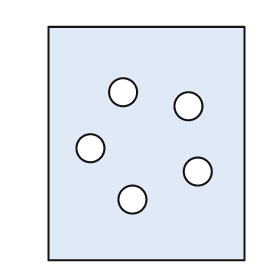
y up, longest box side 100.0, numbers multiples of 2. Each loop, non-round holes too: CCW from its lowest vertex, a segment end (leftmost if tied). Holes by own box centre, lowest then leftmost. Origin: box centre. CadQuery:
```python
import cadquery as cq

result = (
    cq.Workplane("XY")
    .moveTo(-42.0, -50.0)
    .lineTo(42.0, -50.0)
    .lineTo(42.0, 50.0)
    .lineTo(-42.0, 50.0)
    .close()
    .moveTo(-6.0, -24.0)
    .circle(6.0)
    .moveTo(22.0, -12.0)
    .circle(6.0)
    .moveTo(-24.0, -2.0)
    .circle(6.0)
    .moveTo(18.0, 16.0)
    .circle(6.0)
    .moveTo(-10.0, 22.0)
    .circle(6.0)
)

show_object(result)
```